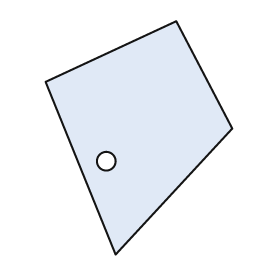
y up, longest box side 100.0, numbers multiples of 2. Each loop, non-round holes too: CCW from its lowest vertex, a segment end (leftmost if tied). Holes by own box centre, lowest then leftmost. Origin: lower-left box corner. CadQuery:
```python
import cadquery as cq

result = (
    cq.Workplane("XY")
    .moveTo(30.0, 0.0)
    .lineTo(80.0, 54.0)
    .lineTo(56.0, 100.0)
    .lineTo(0.0, 74.0)
    .close()
    .moveTo(26.0, 40.0)
    .circle(4.0)
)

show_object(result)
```